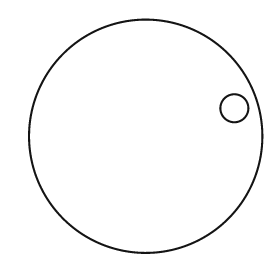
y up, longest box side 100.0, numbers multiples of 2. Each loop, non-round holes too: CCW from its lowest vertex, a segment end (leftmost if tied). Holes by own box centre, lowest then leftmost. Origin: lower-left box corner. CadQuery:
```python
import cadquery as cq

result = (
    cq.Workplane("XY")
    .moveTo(50.0, 50.0)
    .circle(50.0)
    .moveTo(88.0, 62.0)
    .circle(6.0)
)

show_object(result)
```